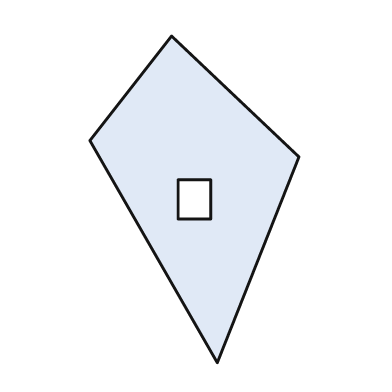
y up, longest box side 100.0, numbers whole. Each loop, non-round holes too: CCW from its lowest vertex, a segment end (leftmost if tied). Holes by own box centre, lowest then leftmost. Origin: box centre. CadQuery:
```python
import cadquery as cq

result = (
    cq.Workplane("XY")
    .moveTo(7.0, -50.0)
    .lineTo(32.0, 13.0)
    .lineTo(-7.0, 50.0)
    .lineTo(-32.0, 18.0)
    .close()
    .moveTo(-5.0, -6.0)
    .lineTo(5.0, -6.0)
    .lineTo(5.0, 6.0)
    .lineTo(-5.0, 6.0)
    .close()
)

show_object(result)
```